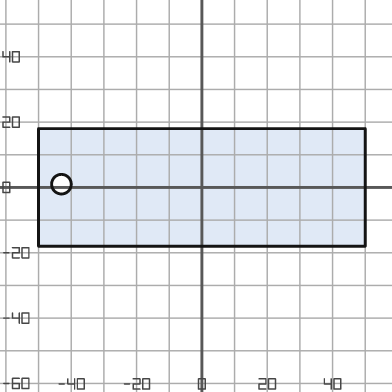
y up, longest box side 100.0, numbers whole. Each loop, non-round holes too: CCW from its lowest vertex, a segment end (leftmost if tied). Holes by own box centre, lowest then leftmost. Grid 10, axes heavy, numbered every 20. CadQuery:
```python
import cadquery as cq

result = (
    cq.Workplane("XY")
    .moveTo(-50.0, -18.0)
    .lineTo(50.0, -18.0)
    .lineTo(50.0, 18.0)
    .lineTo(-50.0, 18.0)
    .close()
    .moveTo(-43.0, 1.0)
    .circle(3.0)
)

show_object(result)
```